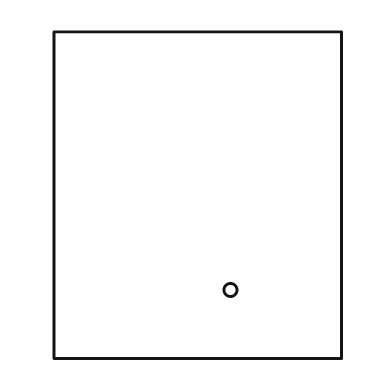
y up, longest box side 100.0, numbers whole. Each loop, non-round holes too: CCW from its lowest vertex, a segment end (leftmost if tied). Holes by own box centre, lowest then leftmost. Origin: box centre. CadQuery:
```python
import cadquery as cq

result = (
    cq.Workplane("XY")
    .moveTo(-44.0, -50.0)
    .lineTo(44.0, -50.0)
    .lineTo(44.0, 50.0)
    .lineTo(-44.0, 50.0)
    .close()
    .moveTo(10.0, -29.0)
    .circle(2.0)
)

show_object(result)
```